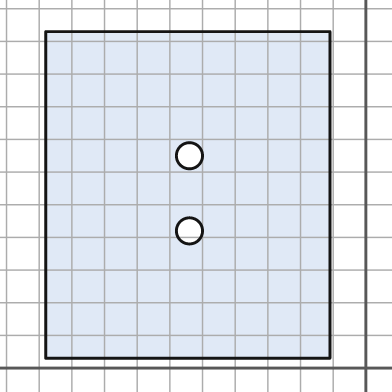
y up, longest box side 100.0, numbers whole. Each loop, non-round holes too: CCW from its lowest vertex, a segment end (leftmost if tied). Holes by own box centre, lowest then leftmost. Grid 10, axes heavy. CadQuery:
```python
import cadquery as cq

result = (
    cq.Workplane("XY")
    .moveTo(-98.0, 3.0)
    .lineTo(-11.0, 3.0)
    .lineTo(-11.0, 103.0)
    .lineTo(-98.0, 103.0)
    .close()
    .moveTo(-54.0, 42.0)
    .circle(4.0)
    .moveTo(-54.0, 65.0)
    .circle(4.0)
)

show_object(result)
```